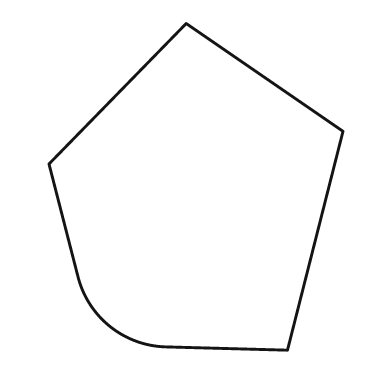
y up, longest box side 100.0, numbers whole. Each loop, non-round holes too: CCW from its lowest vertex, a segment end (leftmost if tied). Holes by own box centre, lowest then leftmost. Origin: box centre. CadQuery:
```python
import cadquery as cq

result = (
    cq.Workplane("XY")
    .moveTo(28.0, -50.0)
    .lineTo(45.0, 17.0)
    .lineTo(-3.0, 50.0)
    .lineTo(-45.0, 7.0)
    .lineTo(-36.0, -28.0)
    .threePointArc((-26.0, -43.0), (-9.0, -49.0))
    .close()
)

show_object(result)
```